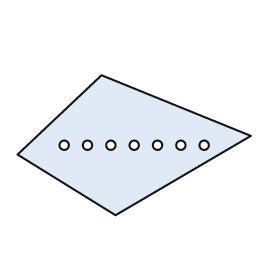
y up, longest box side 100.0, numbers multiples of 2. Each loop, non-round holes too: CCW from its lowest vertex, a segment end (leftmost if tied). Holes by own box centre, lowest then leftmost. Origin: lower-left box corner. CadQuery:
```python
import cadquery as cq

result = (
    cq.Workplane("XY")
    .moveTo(42.0, 0.0)
    .lineTo(100.0, 34.0)
    .lineTo(36.0, 60.0)
    .lineTo(0.0, 26.0)
    .close()
    .moveTo(20.0, 30.0)
    .circle(2.0)
    .moveTo(30.0, 30.0)
    .circle(2.0)
    .moveTo(40.0, 30.0)
    .circle(2.0)
    .moveTo(50.0, 30.0)
    .circle(2.0)
    .moveTo(60.0, 30.0)
    .circle(2.0)
    .moveTo(70.0, 30.0)
    .circle(2.0)
    .moveTo(80.0, 30.0)
    .circle(2.0)
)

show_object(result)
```